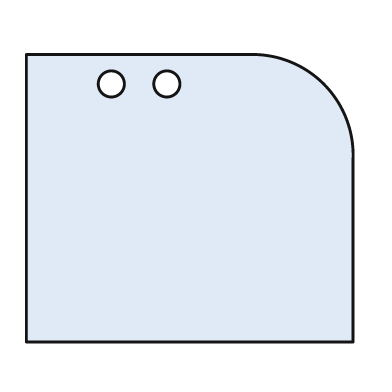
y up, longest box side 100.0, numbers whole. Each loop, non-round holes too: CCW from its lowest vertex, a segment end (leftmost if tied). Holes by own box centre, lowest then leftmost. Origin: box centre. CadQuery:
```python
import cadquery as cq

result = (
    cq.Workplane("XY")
    .moveTo(-50.0, -44.0)
    .lineTo(50.0, -44.0)
    .lineTo(50.0, 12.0)
    .threePointArc((41.0, 35.0), (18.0, 44.0))
    .lineTo(-50.0, 44.0)
    .close()
    .moveTo(-24.0, 35.0)
    .circle(4.0)
    .moveTo(-7.0, 35.0)
    .circle(4.0)
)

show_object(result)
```